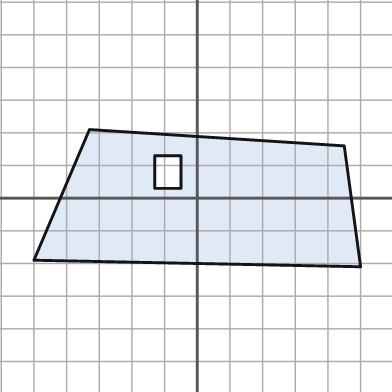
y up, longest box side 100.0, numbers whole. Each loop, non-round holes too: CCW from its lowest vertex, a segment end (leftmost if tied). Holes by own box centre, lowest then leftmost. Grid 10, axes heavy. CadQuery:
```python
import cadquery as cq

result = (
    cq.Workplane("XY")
    .moveTo(50.0, -21.0)
    .lineTo(45.0, 16.0)
    .lineTo(-33.0, 21.0)
    .lineTo(-50.0, -19.0)
    .close()
    .moveTo(-13.0, 3.0)
    .lineTo(-5.0, 3.0)
    .lineTo(-5.0, 13.0)
    .lineTo(-13.0, 13.0)
    .close()
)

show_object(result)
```